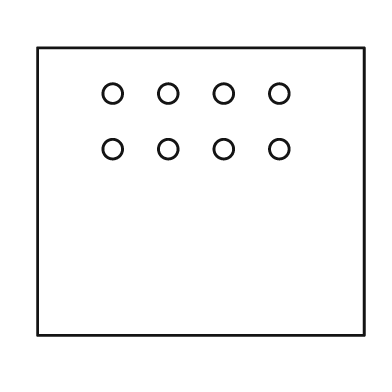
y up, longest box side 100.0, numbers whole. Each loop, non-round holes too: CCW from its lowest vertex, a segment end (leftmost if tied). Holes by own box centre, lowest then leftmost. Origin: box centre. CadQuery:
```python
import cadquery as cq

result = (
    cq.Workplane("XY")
    .moveTo(-50.0, -44.0)
    .lineTo(50.0, -44.0)
    .lineTo(50.0, 44.0)
    .lineTo(-50.0, 44.0)
    .close()
    .moveTo(-27.0, 13.0)
    .circle(3.0)
    .moveTo(-10.0, 13.0)
    .circle(3.0)
    .moveTo(7.0, 13.0)
    .circle(3.0)
    .moveTo(24.0, 13.0)
    .circle(3.0)
    .moveTo(-27.0, 30.0)
    .circle(3.0)
    .moveTo(-10.0, 30.0)
    .circle(3.0)
    .moveTo(7.0, 30.0)
    .circle(3.0)
    .moveTo(24.0, 30.0)
    .circle(3.0)
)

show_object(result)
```